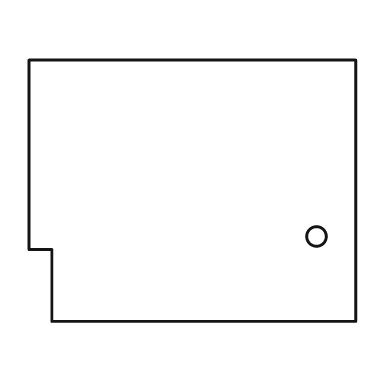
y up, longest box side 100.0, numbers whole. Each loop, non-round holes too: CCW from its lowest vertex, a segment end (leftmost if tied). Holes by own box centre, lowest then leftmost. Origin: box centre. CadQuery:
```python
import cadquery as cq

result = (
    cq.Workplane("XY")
    .moveTo(-43.0, -40.0)
    .lineTo(50.0, -40.0)
    .lineTo(50.0, 40.0)
    .lineTo(-50.0, 40.0)
    .lineTo(-50.0, -18.0)
    .lineTo(-43.0, -18.0)
    .close()
    .moveTo(38.0, -14.0)
    .circle(3.0)
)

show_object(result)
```